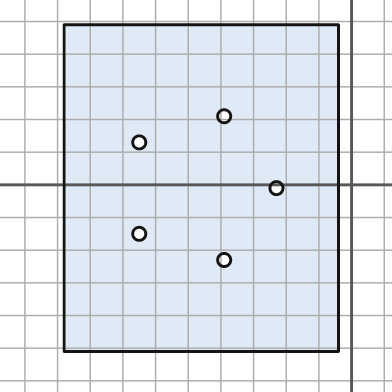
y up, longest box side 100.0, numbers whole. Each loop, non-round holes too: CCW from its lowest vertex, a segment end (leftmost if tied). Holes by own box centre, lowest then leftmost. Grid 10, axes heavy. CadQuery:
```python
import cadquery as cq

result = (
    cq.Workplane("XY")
    .moveTo(-88.0, -51.0)
    .lineTo(-4.0, -51.0)
    .lineTo(-4.0, 49.0)
    .lineTo(-88.0, 49.0)
    .close()
    .moveTo(-39.0, -23.0)
    .circle(2.0)
    .moveTo(-65.0, -15.0)
    .circle(2.0)
    .moveTo(-23.0, -1.0)
    .circle(2.0)
    .moveTo(-65.0, 13.0)
    .circle(2.0)
    .moveTo(-39.0, 21.0)
    .circle(2.0)
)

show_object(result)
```